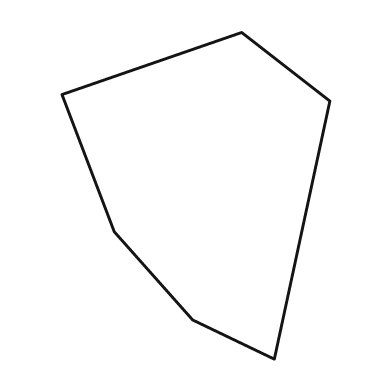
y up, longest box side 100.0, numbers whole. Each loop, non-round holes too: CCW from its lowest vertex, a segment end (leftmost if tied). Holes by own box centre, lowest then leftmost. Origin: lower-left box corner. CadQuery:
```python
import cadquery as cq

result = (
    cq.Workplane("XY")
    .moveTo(65.0, 0.0)
    .lineTo(82.0, 79.0)
    .lineTo(55.0, 100.0)
    .lineTo(0.0, 81.0)
    .lineTo(16.0, 39.0)
    .lineTo(40.0, 12.0)
    .close()
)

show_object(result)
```